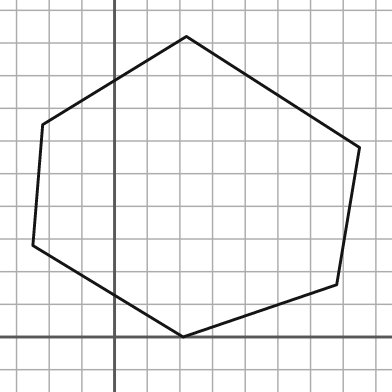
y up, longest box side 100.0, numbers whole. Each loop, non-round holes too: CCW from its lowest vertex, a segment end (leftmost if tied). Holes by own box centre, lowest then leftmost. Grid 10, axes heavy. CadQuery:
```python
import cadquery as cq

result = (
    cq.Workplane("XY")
    .moveTo(21.0, 0.0)
    .lineTo(68.0, 16.0)
    .lineTo(75.0, 58.0)
    .lineTo(22.0, 92.0)
    .lineTo(-22.0, 65.0)
    .lineTo(-25.0, 28.0)
    .close()
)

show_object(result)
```